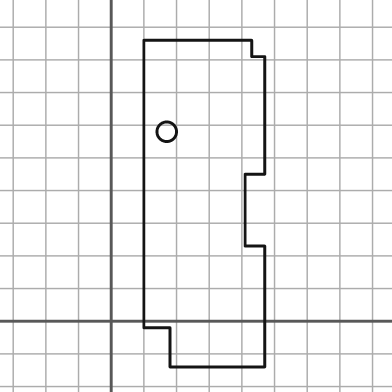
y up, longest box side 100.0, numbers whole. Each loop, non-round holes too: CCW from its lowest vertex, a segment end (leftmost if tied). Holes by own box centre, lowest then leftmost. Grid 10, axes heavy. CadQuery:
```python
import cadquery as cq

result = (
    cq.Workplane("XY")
    .moveTo(18.0, -14.0)
    .lineTo(47.0, -14.0)
    .lineTo(47.0, 23.0)
    .lineTo(41.0, 23.0)
    .lineTo(41.0, 45.0)
    .lineTo(47.0, 45.0)
    .lineTo(47.0, 81.0)
    .lineTo(43.0, 81.0)
    .lineTo(43.0, 86.0)
    .lineTo(10.0, 86.0)
    .lineTo(10.0, -2.0)
    .lineTo(18.0, -2.0)
    .close()
    .moveTo(17.0, 58.0)
    .circle(3.0)
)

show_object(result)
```